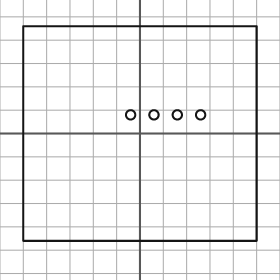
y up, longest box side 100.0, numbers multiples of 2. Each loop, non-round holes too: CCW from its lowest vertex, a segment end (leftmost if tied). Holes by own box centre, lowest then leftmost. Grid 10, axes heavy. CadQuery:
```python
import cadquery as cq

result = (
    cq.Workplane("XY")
    .moveTo(-50.0, -46.0)
    .lineTo(50.0, -46.0)
    .lineTo(50.0, 46.0)
    .lineTo(-50.0, 46.0)
    .close()
    .moveTo(-4.0, 8.0)
    .circle(2.0)
    .moveTo(6.0, 8.0)
    .circle(2.0)
    .moveTo(16.0, 8.0)
    .circle(2.0)
    .moveTo(26.0, 8.0)
    .circle(2.0)
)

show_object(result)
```